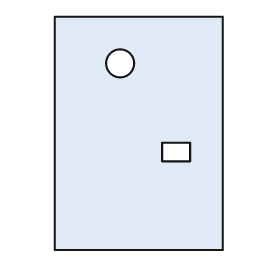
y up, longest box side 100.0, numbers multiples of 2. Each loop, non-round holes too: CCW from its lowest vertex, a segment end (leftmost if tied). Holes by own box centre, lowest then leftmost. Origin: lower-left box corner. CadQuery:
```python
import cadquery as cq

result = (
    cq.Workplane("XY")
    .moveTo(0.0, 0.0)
    .lineTo(72.0, 0.0)
    .lineTo(72.0, 100.0)
    .lineTo(0.0, 100.0)
    .close()
    .moveTo(46.0, 38.0)
    .lineTo(58.0, 38.0)
    .lineTo(58.0, 46.0)
    .lineTo(46.0, 46.0)
    .close()
    .moveTo(28.0, 80.0)
    .circle(6.0)
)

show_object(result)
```